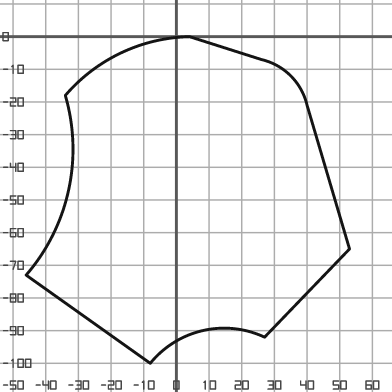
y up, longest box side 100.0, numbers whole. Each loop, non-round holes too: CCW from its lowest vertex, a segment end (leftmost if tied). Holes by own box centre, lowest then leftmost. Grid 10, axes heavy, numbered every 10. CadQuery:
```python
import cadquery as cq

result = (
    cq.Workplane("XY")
    .moveTo(-8.0, -100.0)
    .threePointArc((8.0, -90.0), (27.0, -92.0))
    .lineTo(53.0, -65.0)
    .lineTo(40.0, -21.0)
    .threePointArc((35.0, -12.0), (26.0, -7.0))
    .lineTo(4.0, 0.0)
    .threePointArc((-17.0, -5.0), (-34.0, -18.0))
    .threePointArc((-33.0, -47.0), (-46.0, -73.0))
    .close()
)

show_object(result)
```